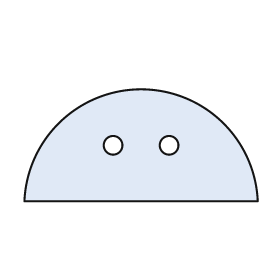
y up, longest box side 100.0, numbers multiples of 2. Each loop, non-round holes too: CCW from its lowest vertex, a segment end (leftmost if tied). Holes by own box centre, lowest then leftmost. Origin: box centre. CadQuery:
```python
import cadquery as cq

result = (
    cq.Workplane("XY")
    .moveTo(-50.0, -24.0)
    .lineTo(50.0, -24.0)
    .threePointArc((0.0, 24.0), (-50.0, -24.0))
    .close()
    .moveTo(-12.0, 0.0)
    .circle(4.0)
    .moveTo(12.0, 0.0)
    .circle(4.0)
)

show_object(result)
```